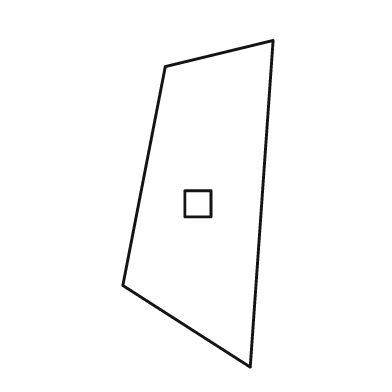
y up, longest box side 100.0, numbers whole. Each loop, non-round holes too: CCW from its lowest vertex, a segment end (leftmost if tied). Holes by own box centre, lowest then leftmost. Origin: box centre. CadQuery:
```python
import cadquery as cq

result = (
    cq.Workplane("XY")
    .moveTo(16.0, -50.0)
    .lineTo(23.0, 50.0)
    .lineTo(-10.0, 42.0)
    .lineTo(-23.0, -25.0)
    .close()
    .moveTo(-4.0, -4.0)
    .lineTo(4.0, -4.0)
    .lineTo(4.0, 4.0)
    .lineTo(-4.0, 4.0)
    .close()
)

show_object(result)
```